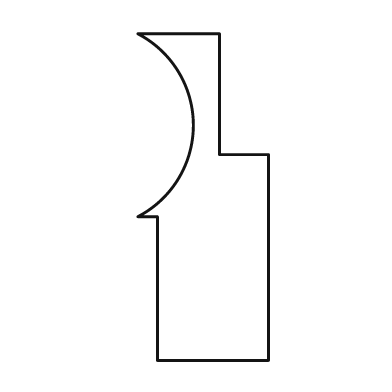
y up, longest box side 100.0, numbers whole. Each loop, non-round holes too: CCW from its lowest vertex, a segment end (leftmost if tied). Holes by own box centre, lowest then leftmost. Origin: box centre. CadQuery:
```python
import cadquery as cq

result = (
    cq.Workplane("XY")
    .moveTo(-14.0, -50.0)
    .lineTo(20.0, -50.0)
    .lineTo(20.0, 13.0)
    .lineTo(5.0, 13.0)
    .lineTo(5.0, 50.0)
    .lineTo(-20.0, 50.0)
    .threePointArc((-3.0, 22.0), (-20.0, -6.0))
    .lineTo(-14.0, -6.0)
    .close()
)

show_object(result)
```